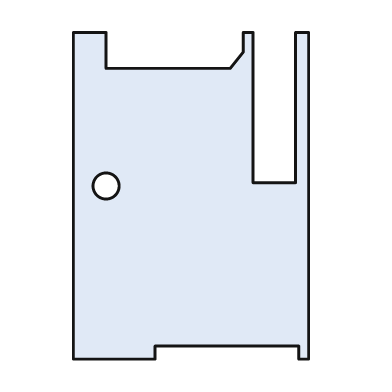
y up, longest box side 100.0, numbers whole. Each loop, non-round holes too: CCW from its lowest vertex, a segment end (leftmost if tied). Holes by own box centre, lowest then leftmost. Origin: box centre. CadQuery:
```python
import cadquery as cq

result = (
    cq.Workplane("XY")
    .moveTo(-36.0, -50.0)
    .lineTo(-11.0, -50.0)
    .lineTo(-11.0, -46.0)
    .lineTo(33.0, -46.0)
    .lineTo(33.0, -50.0)
    .lineTo(36.0, -50.0)
    .lineTo(36.0, 50.0)
    .lineTo(32.0, 50.0)
    .lineTo(32.0, 4.0)
    .lineTo(19.0, 4.0)
    .lineTo(19.0, 50.0)
    .lineTo(16.0, 50.0)
    .lineTo(16.0, 44.0)
    .lineTo(12.0, 39.0)
    .lineTo(-26.0, 39.0)
    .lineTo(-26.0, 50.0)
    .lineTo(-36.0, 50.0)
    .close()
    .moveTo(-26.0, 3.0)
    .circle(4.0)
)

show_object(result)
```